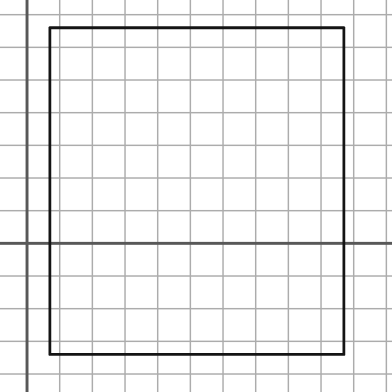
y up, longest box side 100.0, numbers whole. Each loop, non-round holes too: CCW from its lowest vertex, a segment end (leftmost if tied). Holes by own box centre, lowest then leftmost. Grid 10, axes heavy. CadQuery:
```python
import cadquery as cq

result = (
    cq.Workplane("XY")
    .moveTo(7.0, -34.0)
    .lineTo(97.0, -34.0)
    .lineTo(97.0, 66.0)
    .lineTo(7.0, 66.0)
    .close()
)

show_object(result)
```